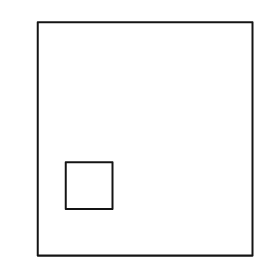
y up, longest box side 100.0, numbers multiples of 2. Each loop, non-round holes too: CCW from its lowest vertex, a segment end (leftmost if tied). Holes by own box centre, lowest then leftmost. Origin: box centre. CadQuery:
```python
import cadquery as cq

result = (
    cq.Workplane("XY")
    .moveTo(-46.0, -50.0)
    .lineTo(46.0, -50.0)
    .lineTo(46.0, 50.0)
    .lineTo(-46.0, 50.0)
    .close()
    .moveTo(-34.0, -30.0)
    .lineTo(-14.0, -30.0)
    .lineTo(-14.0, -10.0)
    .lineTo(-34.0, -10.0)
    .close()
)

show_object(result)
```